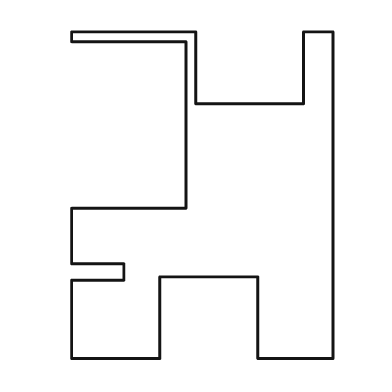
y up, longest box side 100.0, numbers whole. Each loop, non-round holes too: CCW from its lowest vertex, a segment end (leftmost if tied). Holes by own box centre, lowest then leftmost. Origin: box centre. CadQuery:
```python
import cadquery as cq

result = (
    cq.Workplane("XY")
    .moveTo(-40.0, -50.0)
    .lineTo(-13.0, -50.0)
    .lineTo(-13.0, -25.0)
    .lineTo(17.0, -25.0)
    .lineTo(17.0, -50.0)
    .lineTo(40.0, -50.0)
    .lineTo(40.0, 50.0)
    .lineTo(31.0, 50.0)
    .lineTo(31.0, 28.0)
    .lineTo(-2.0, 28.0)
    .lineTo(-2.0, 50.0)
    .lineTo(-40.0, 50.0)
    .lineTo(-40.0, 47.0)
    .lineTo(-5.0, 47.0)
    .lineTo(-5.0, -4.0)
    .lineTo(-40.0, -4.0)
    .lineTo(-40.0, -21.0)
    .lineTo(-24.0, -21.0)
    .lineTo(-24.0, -26.0)
    .lineTo(-40.0, -26.0)
    .close()
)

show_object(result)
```